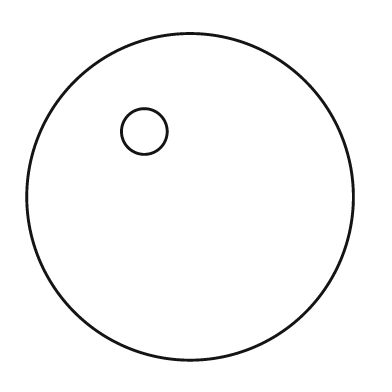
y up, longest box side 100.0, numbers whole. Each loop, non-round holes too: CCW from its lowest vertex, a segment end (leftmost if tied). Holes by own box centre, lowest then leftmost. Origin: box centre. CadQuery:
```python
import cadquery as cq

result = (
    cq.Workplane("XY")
    .moveTo(0.0, 0.0)
    .circle(50.0)
    .moveTo(-14.0, 20.0)
    .circle(7.0)
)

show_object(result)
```